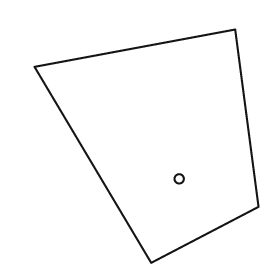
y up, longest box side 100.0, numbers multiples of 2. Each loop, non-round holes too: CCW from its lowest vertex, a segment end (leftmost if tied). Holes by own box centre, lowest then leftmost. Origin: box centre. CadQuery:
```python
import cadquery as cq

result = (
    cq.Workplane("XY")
    .moveTo(2.0, -50.0)
    .lineTo(48.0, -26.0)
    .lineTo(38.0, 50.0)
    .lineTo(-48.0, 34.0)
    .close()
    .moveTo(14.0, -14.0)
    .circle(2.0)
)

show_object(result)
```